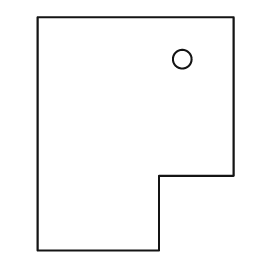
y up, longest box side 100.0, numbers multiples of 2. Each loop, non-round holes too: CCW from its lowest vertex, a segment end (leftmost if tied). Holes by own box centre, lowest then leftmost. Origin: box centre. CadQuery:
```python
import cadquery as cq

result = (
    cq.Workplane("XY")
    .moveTo(-42.0, -50.0)
    .lineTo(10.0, -50.0)
    .lineTo(10.0, -18.0)
    .lineTo(42.0, -18.0)
    .lineTo(42.0, 50.0)
    .lineTo(-42.0, 50.0)
    .close()
    .moveTo(20.0, 32.0)
    .circle(4.0)
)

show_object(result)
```